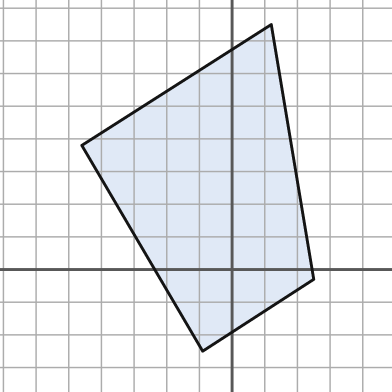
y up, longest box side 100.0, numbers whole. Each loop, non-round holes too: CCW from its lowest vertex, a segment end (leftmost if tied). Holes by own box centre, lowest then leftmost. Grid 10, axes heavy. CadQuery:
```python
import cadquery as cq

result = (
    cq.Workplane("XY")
    .moveTo(-9.0, -25.0)
    .lineTo(25.0, -3.0)
    .lineTo(12.0, 75.0)
    .lineTo(-46.0, 38.0)
    .close()
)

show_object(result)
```